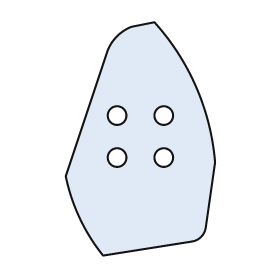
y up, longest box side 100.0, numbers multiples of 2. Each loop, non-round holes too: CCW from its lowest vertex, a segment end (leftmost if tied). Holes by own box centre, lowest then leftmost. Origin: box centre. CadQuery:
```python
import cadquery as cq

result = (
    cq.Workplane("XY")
    .moveTo(-16.0, -50.0)
    .lineTo(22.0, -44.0)
    .threePointArc((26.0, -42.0), (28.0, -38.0))
    .lineTo(32.0, -10.0)
    .threePointArc((24.0, 22.0), (6.0, 50.0))
    .lineTo(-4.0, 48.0)
    .threePointArc((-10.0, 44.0), (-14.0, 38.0))
    .lineTo(-32.0, -16.0)
    .threePointArc((-26.0, -34.0), (-16.0, -50.0))
    .close()
    .moveTo(-10.0, -8.0)
    .circle(4.0)
    .moveTo(10.0, -8.0)
    .circle(4.0)
    .moveTo(-10.0, 10.0)
    .circle(4.0)
    .moveTo(10.0, 10.0)
    .circle(4.0)
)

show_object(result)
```